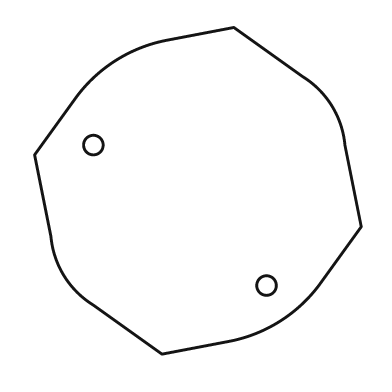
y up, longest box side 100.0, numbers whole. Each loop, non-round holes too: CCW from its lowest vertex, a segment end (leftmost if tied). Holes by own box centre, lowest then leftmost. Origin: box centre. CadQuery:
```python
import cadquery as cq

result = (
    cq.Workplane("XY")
    .moveTo(-11.0, -50.0)
    .lineTo(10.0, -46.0)
    .threePointArc((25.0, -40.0), (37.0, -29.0))
    .lineTo(50.0, -11.0)
    .lineTo(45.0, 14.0)
    .threePointArc((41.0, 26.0), (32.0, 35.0))
    .lineTo(11.0, 50.0)
    .lineTo(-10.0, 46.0)
    .threePointArc((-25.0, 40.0), (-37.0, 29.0))
    .lineTo(-50.0, 11.0)
    .lineTo(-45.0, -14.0)
    .threePointArc((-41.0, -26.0), (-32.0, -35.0))
    .close()
    .moveTo(21.0, -29.0)
    .circle(3.0)
    .moveTo(-32.0, 14.0)
    .circle(3.0)
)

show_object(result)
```